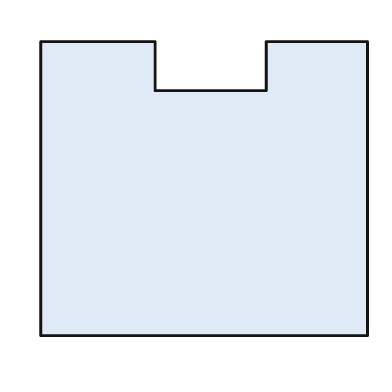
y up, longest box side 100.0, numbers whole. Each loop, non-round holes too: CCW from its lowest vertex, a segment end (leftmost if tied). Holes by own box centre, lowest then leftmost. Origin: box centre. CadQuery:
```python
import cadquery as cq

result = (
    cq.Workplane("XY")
    .moveTo(-50.0, -45.0)
    .lineTo(50.0, -45.0)
    .lineTo(50.0, 45.0)
    .lineTo(19.0, 45.0)
    .lineTo(19.0, 30.0)
    .lineTo(-15.0, 30.0)
    .lineTo(-15.0, 45.0)
    .lineTo(-50.0, 45.0)
    .close()
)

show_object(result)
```